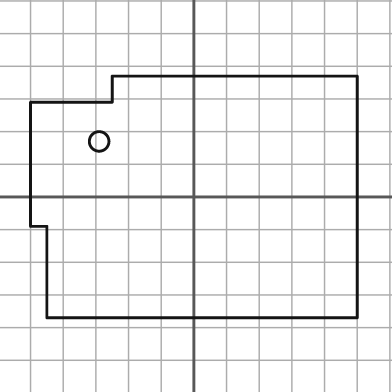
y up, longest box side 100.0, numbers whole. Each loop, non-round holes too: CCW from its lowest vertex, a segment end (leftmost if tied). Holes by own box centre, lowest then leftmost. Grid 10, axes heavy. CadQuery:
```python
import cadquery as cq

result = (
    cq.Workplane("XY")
    .moveTo(-45.0, -37.0)
    .lineTo(50.0, -37.0)
    .lineTo(50.0, 37.0)
    .lineTo(-25.0, 37.0)
    .lineTo(-25.0, 29.0)
    .lineTo(-50.0, 29.0)
    .lineTo(-50.0, -9.0)
    .lineTo(-45.0, -9.0)
    .close()
    .moveTo(-29.0, 17.0)
    .circle(3.0)
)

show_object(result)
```